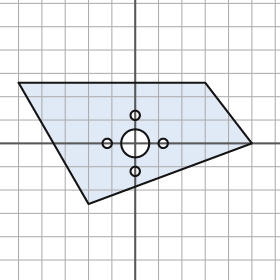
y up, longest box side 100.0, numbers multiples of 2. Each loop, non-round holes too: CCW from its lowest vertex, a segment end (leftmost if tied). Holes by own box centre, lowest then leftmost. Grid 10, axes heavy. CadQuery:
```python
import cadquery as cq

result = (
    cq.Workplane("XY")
    .moveTo(-20.0, -26.0)
    .lineTo(50.0, 0.0)
    .lineTo(30.0, 26.0)
    .lineTo(-50.0, 26.0)
    .close()
    .moveTo(0.0, -12.0)
    .circle(2.0)
    .moveTo(-12.0, 0.0)
    .circle(2.0)
    .moveTo(0.0, 0.0)
    .circle(6.0)
    .moveTo(12.0, 0.0)
    .circle(2.0)
    .moveTo(0.0, 12.0)
    .circle(2.0)
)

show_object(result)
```